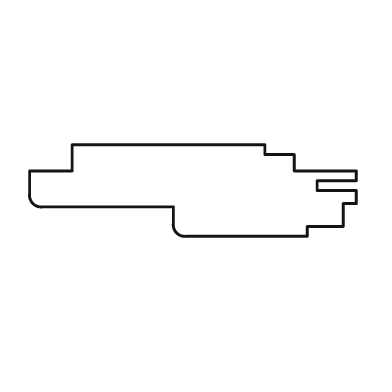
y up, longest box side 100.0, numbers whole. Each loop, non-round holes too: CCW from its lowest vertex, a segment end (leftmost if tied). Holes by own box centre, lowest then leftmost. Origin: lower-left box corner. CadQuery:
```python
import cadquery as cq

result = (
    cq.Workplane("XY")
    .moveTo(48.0, 0.0)
    .lineTo(85.0, 0.0)
    .lineTo(85.0, 3.0)
    .lineTo(96.0, 3.0)
    .lineTo(96.0, 10.0)
    .lineTo(100.0, 10.0)
    .lineTo(100.0, 14.0)
    .lineTo(88.0, 14.0)
    .lineTo(88.0, 17.0)
    .lineTo(100.0, 17.0)
    .lineTo(100.0, 20.0)
    .lineTo(81.0, 20.0)
    .lineTo(81.0, 25.0)
    .lineTo(72.0, 25.0)
    .lineTo(72.0, 28.0)
    .lineTo(13.0, 28.0)
    .lineTo(13.0, 20.0)
    .lineTo(0.0, 20.0)
    .lineTo(0.0, 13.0)
    .threePointArc((1.0, 10.0), (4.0, 9.0))
    .lineTo(44.0, 9.0)
    .lineTo(44.0, 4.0)
    .threePointArc((45.0, 1.0), (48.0, 0.0))
    .close()
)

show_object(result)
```